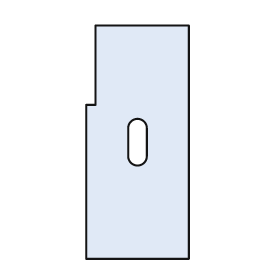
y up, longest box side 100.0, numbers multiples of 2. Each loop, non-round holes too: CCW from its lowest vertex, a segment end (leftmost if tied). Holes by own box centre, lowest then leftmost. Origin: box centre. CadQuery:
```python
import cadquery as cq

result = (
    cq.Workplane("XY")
    .moveTo(-22.0, -50.0)
    .lineTo(22.0, -50.0)
    .lineTo(22.0, 50.0)
    .lineTo(-18.0, 50.0)
    .lineTo(-18.0, 16.0)
    .lineTo(-22.0, 16.0)
    .close()
    .moveTo(-4.0, -6.0)
    .threePointArc((0.0, -10.0), (4.0, -6.0))
    .lineTo(4.0, 6.0)
    .threePointArc((0.0, 10.0), (-4.0, 6.0))
    .close()
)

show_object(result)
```